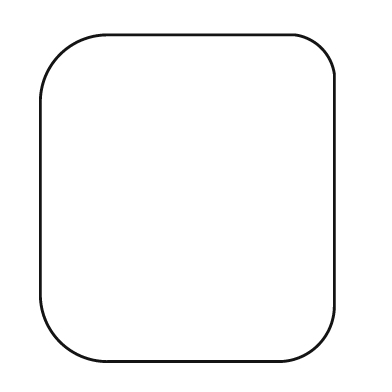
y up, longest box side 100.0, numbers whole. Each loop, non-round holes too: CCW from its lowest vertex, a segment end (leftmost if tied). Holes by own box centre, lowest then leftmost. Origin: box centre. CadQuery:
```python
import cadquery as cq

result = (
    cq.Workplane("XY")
    .moveTo(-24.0, -50.0)
    .lineTo(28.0, -50.0)
    .threePointArc((40.0, -45.0), (45.0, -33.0))
    .lineTo(45.0, 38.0)
    .threePointArc((41.0, 46.0), (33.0, 50.0))
    .lineTo(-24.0, 50.0)
    .threePointArc((-39.0, 44.0), (-45.0, 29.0))
    .lineTo(-45.0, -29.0)
    .threePointArc((-39.0, -44.0), (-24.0, -50.0))
    .close()
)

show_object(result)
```